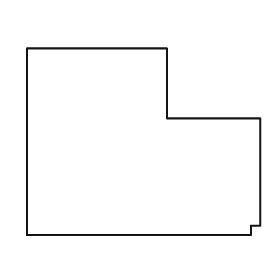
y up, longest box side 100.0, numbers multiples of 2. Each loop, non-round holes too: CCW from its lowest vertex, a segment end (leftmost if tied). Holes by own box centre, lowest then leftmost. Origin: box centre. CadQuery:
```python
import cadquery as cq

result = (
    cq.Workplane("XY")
    .moveTo(-50.0, -40.0)
    .lineTo(46.0, -40.0)
    .lineTo(46.0, -36.0)
    .lineTo(50.0, -36.0)
    .lineTo(50.0, 10.0)
    .lineTo(10.0, 10.0)
    .lineTo(10.0, 40.0)
    .lineTo(-50.0, 40.0)
    .close()
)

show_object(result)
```